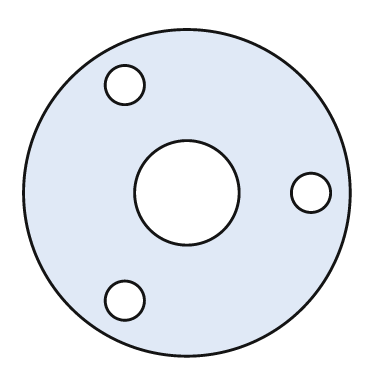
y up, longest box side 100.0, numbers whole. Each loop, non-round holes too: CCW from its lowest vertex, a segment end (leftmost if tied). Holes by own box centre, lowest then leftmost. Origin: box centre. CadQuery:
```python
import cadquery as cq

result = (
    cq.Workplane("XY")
    .moveTo(0.0, 0.0)
    .circle(50.0)
    .moveTo(-19.0, -33.0)
    .circle(6.0)
    .moveTo(0.0, 0.0)
    .circle(16.0)
    .moveTo(38.0, 0.0)
    .circle(6.0)
    .moveTo(-19.0, 33.0)
    .circle(6.0)
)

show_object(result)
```